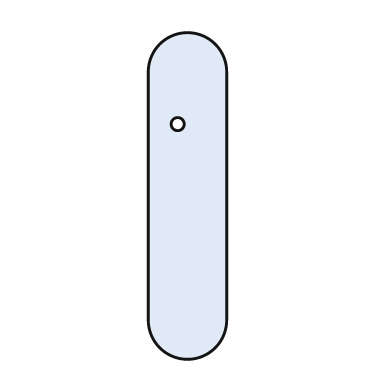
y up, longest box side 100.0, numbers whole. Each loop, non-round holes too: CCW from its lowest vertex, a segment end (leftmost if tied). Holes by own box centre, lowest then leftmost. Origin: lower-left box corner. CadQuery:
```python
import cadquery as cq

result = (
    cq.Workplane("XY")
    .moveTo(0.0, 12.0)
    .threePointArc((12.0, 0.0), (24.0, 12.0))
    .lineTo(24.0, 88.0)
    .threePointArc((12.0, 100.0), (0.0, 88.0))
    .close()
    .moveTo(9.0, 72.0)
    .circle(2.0)
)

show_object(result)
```